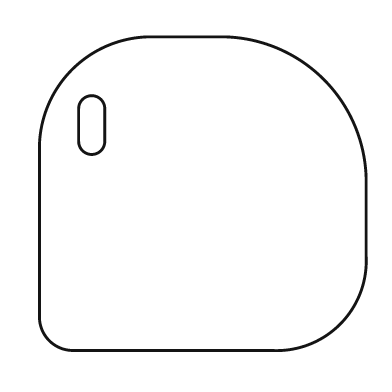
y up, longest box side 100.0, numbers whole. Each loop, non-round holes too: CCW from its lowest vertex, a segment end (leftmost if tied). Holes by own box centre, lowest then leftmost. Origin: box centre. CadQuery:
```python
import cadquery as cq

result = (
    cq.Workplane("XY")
    .moveTo(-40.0, -48.0)
    .lineTo(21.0, -48.0)
    .threePointArc((42.0, -40.0), (50.0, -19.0))
    .lineTo(50.0, 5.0)
    .threePointArc((37.0, 35.0), (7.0, 48.0))
    .lineTo(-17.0, 48.0)
    .threePointArc((-40.0, 38.0), (-50.0, 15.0))
    .lineTo(-50.0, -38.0)
    .threePointArc((-47.0, -45.0), (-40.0, -48.0))
    .close()
    .moveTo(-38.0, 16.0)
    .threePointArc((-34.0, 12.0), (-30.0, 16.0))
    .lineTo(-30.0, 26.0)
    .threePointArc((-34.0, 30.0), (-38.0, 26.0))
    .close()
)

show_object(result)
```